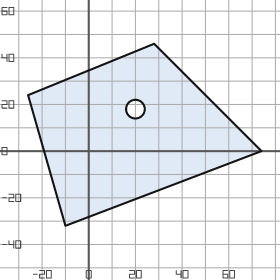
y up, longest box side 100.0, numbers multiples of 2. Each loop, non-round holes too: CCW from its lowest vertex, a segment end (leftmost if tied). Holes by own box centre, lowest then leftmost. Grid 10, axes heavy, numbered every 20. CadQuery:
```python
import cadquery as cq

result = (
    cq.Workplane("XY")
    .moveTo(-10.0, -32.0)
    .lineTo(74.0, 0.0)
    .lineTo(28.0, 46.0)
    .lineTo(-26.0, 24.0)
    .close()
    .moveTo(20.0, 18.0)
    .circle(4.0)
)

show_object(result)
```